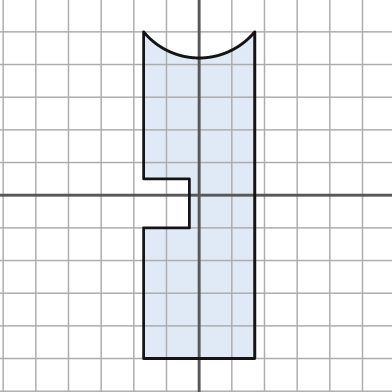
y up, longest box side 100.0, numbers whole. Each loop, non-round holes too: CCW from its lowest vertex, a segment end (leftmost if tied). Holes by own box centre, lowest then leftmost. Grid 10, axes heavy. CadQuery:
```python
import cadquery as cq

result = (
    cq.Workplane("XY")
    .moveTo(-17.0, -50.0)
    .lineTo(17.0, -50.0)
    .lineTo(17.0, 50.0)
    .threePointArc((0.0, 42.0), (-17.0, 50.0))
    .lineTo(-17.0, 5.0)
    .lineTo(-3.0, 5.0)
    .lineTo(-3.0, -10.0)
    .lineTo(-17.0, -10.0)
    .close()
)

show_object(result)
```